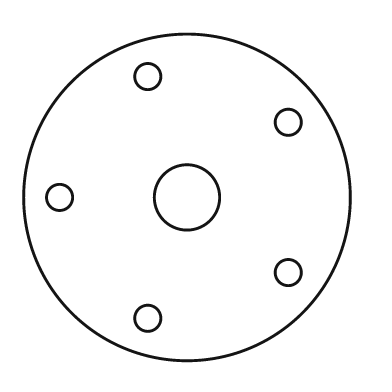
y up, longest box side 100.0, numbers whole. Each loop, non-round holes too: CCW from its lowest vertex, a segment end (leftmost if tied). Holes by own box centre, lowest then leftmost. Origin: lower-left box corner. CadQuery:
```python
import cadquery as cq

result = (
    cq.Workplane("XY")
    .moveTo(50.0, 50.0)
    .circle(50.0)
    .moveTo(38.0, 13.0)
    .circle(4.0)
    .moveTo(81.0, 27.0)
    .circle(4.0)
    .moveTo(11.0, 50.0)
    .circle(4.0)
    .moveTo(50.0, 50.0)
    .circle(10.0)
    .moveTo(81.0, 73.0)
    .circle(4.0)
    .moveTo(38.0, 87.0)
    .circle(4.0)
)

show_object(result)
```